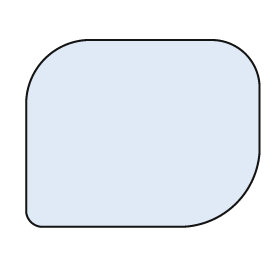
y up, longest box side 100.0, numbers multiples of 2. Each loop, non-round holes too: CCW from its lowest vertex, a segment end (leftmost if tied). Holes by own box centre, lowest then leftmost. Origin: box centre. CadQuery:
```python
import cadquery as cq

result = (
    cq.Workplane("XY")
    .moveTo(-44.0, -40.0)
    .lineTo(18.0, -40.0)
    .threePointArc((40.0, -30.0), (50.0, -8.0))
    .lineTo(50.0, 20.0)
    .threePointArc((44.0, 34.0), (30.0, 40.0))
    .lineTo(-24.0, 40.0)
    .threePointArc((-42.0, 32.0), (-50.0, 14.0))
    .lineTo(-50.0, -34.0)
    .threePointArc((-48.0, -38.0), (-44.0, -40.0))
    .close()
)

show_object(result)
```